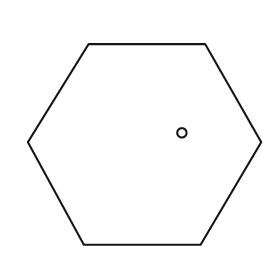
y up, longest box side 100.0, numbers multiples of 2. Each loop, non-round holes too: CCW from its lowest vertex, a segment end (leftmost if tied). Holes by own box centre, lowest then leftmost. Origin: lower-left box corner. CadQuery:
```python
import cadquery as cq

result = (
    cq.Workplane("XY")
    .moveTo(24.0, 0.0)
    .lineTo(74.0, 0.0)
    .lineTo(100.0, 44.0)
    .lineTo(76.0, 86.0)
    .lineTo(26.0, 86.0)
    .lineTo(0.0, 44.0)
    .close()
    .moveTo(66.0, 48.0)
    .circle(2.0)
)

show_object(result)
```